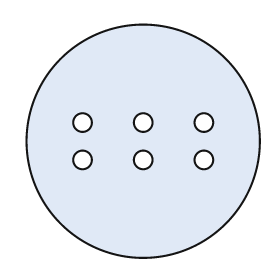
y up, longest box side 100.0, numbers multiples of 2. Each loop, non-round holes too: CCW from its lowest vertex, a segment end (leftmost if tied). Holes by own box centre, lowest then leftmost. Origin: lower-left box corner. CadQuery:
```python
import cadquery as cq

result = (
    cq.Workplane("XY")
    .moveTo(50.0, 50.0)
    .circle(50.0)
    .moveTo(24.0, 42.0)
    .circle(4.0)
    .moveTo(50.0, 42.0)
    .circle(4.0)
    .moveTo(76.0, 42.0)
    .circle(4.0)
    .moveTo(24.0, 58.0)
    .circle(4.0)
    .moveTo(50.0, 58.0)
    .circle(4.0)
    .moveTo(76.0, 58.0)
    .circle(4.0)
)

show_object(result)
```